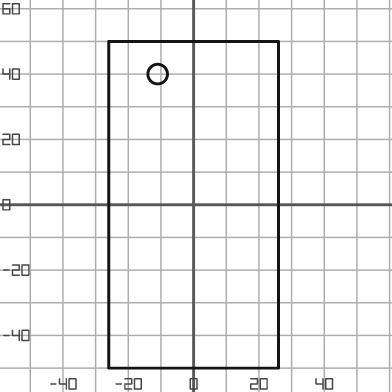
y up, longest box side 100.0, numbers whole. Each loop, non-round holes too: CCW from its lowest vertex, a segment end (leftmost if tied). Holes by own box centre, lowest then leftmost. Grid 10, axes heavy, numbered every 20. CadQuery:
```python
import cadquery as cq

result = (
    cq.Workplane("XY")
    .moveTo(-26.0, -50.0)
    .lineTo(26.0, -50.0)
    .lineTo(26.0, 50.0)
    .lineTo(-26.0, 50.0)
    .close()
    .moveTo(-11.0, 40.0)
    .circle(3.0)
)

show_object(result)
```